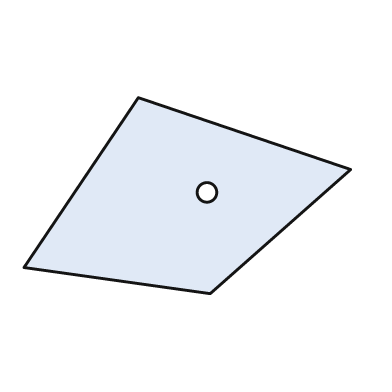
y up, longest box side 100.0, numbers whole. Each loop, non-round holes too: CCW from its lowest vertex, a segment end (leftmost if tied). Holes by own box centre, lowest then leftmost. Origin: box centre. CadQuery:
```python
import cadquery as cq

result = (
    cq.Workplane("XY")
    .moveTo(7.0, -30.0)
    .lineTo(50.0, 8.0)
    .lineTo(-15.0, 30.0)
    .lineTo(-50.0, -22.0)
    .close()
    .moveTo(6.0, 1.0)
    .circle(3.0)
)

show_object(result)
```